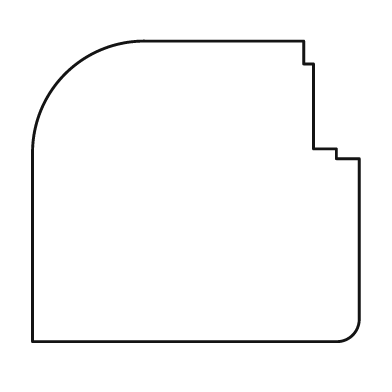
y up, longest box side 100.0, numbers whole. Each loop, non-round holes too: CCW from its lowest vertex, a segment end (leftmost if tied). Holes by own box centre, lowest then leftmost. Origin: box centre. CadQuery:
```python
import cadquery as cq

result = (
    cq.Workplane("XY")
    .moveTo(-50.0, -46.0)
    .lineTo(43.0, -46.0)
    .threePointArc((48.0, -44.0), (50.0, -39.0))
    .lineTo(50.0, 10.0)
    .lineTo(43.0, 10.0)
    .lineTo(43.0, 13.0)
    .lineTo(36.0, 13.0)
    .lineTo(36.0, 39.0)
    .lineTo(33.0, 39.0)
    .lineTo(33.0, 46.0)
    .lineTo(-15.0, 46.0)
    .threePointArc((-40.0, 36.0), (-50.0, 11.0))
    .close()
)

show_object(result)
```